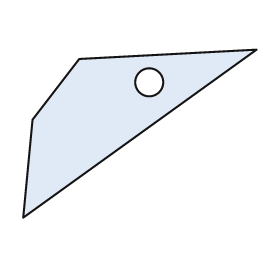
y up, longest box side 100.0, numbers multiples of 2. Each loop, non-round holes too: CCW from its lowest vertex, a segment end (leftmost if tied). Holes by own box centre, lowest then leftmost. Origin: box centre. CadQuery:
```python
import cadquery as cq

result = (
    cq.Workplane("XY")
    .moveTo(-50.0, -36.0)
    .lineTo(50.0, 36.0)
    .lineTo(-26.0, 32.0)
    .lineTo(-46.0, 6.0)
    .close()
    .moveTo(4.0, 22.0)
    .circle(6.0)
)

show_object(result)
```